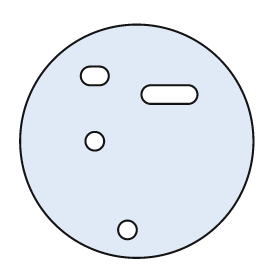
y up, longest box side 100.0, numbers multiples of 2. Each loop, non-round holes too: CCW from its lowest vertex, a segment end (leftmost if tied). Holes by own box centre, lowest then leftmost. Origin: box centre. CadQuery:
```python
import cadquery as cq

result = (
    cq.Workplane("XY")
    .moveTo(0.0, 0.0)
    .circle(50.0)
    .moveTo(-4.0, -38.0)
    .circle(4.0)
    .moveTo(-18.0, 0.0)
    .circle(4.0)
    .moveTo(6.0, 16.0)
    .lineTo(22.0, 16.0)
    .threePointArc((26.0, 20.0), (22.0, 24.0))
    .lineTo(6.0, 24.0)
    .threePointArc((2.0, 20.0), (6.0, 16.0))
    .close()
    .moveTo(-20.0, 24.0)
    .lineTo(-16.0, 24.0)
    .threePointArc((-12.0, 28.0), (-16.0, 32.0))
    .lineTo(-20.0, 32.0)
    .threePointArc((-24.0, 28.0), (-20.0, 24.0))
    .close()
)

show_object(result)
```